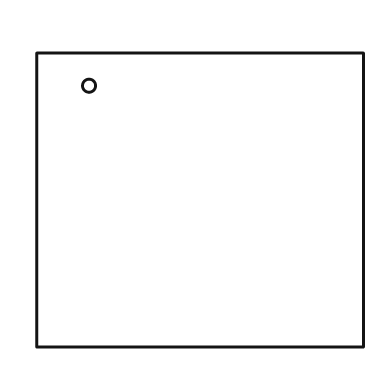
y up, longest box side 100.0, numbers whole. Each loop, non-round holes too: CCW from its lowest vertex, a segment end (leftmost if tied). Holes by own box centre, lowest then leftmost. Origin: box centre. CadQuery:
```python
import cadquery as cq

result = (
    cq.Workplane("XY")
    .moveTo(-50.0, -45.0)
    .lineTo(50.0, -45.0)
    .lineTo(50.0, 45.0)
    .lineTo(-50.0, 45.0)
    .close()
    .moveTo(-34.0, 35.0)
    .circle(2.0)
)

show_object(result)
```